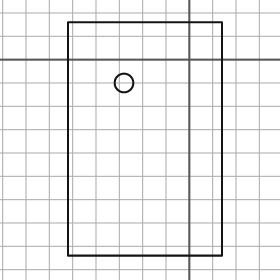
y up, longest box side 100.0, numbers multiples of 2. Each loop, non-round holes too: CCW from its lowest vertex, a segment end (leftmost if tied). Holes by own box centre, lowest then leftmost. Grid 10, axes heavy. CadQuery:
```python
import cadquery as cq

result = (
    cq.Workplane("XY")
    .moveTo(-52.0, -84.0)
    .lineTo(14.0, -84.0)
    .lineTo(14.0, 16.0)
    .lineTo(-52.0, 16.0)
    .close()
    .moveTo(-28.0, -10.0)
    .circle(4.0)
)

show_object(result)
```